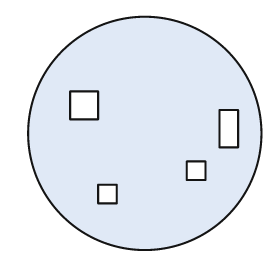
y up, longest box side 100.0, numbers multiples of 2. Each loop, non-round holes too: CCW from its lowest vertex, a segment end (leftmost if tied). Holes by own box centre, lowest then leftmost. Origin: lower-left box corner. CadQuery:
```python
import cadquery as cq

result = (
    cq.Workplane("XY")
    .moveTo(50.0, 50.0)
    .circle(50.0)
    .moveTo(30.0, 20.0)
    .lineTo(38.0, 20.0)
    .lineTo(38.0, 28.0)
    .lineTo(30.0, 28.0)
    .close()
    .moveTo(68.0, 30.0)
    .lineTo(76.0, 30.0)
    .lineTo(76.0, 38.0)
    .lineTo(68.0, 38.0)
    .close()
    .moveTo(82.0, 44.0)
    .lineTo(90.0, 44.0)
    .lineTo(90.0, 60.0)
    .lineTo(82.0, 60.0)
    .close()
    .moveTo(18.0, 56.0)
    .lineTo(30.0, 56.0)
    .lineTo(30.0, 68.0)
    .lineTo(18.0, 68.0)
    .close()
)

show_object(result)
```